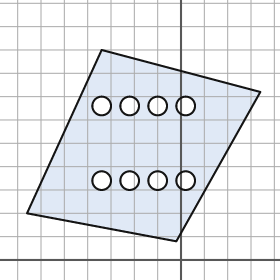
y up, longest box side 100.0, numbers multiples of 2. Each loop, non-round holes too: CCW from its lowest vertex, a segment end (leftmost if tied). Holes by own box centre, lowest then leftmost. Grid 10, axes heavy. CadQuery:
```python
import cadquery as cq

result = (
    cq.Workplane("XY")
    .moveTo(-2.0, 8.0)
    .lineTo(34.0, 72.0)
    .lineTo(-34.0, 90.0)
    .lineTo(-66.0, 20.0)
    .close()
    .moveTo(-34.0, 34.0)
    .circle(4.0)
    .moveTo(-22.0, 34.0)
    .circle(4.0)
    .moveTo(-10.0, 34.0)
    .circle(4.0)
    .moveTo(2.0, 34.0)
    .circle(4.0)
    .moveTo(-34.0, 66.0)
    .circle(4.0)
    .moveTo(-22.0, 66.0)
    .circle(4.0)
    .moveTo(-10.0, 66.0)
    .circle(4.0)
    .moveTo(2.0, 66.0)
    .circle(4.0)
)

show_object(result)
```